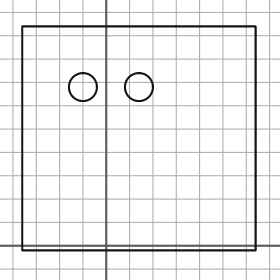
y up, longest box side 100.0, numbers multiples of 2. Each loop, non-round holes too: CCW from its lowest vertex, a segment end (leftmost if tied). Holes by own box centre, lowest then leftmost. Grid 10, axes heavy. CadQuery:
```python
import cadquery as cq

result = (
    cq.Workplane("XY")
    .moveTo(-36.0, -2.0)
    .lineTo(64.0, -2.0)
    .lineTo(64.0, 94.0)
    .lineTo(-36.0, 94.0)
    .close()
    .moveTo(-10.0, 68.0)
    .circle(6.0)
    .moveTo(14.0, 68.0)
    .circle(6.0)
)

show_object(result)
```